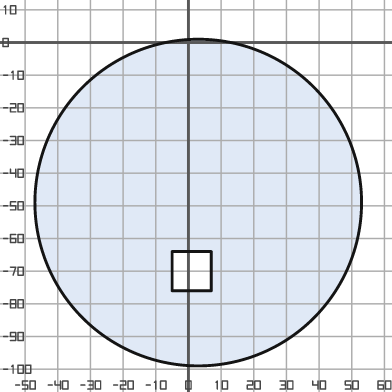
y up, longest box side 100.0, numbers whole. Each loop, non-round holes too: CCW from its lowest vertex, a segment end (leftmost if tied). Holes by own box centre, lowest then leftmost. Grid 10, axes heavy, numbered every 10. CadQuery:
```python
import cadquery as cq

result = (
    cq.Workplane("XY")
    .moveTo(3.0, -49.0)
    .circle(50.0)
    .moveTo(-5.0, -76.0)
    .lineTo(7.0, -76.0)
    .lineTo(7.0, -64.0)
    .lineTo(-5.0, -64.0)
    .close()
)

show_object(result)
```